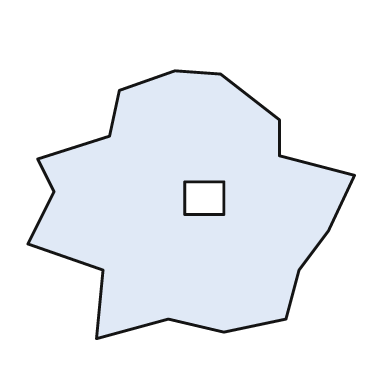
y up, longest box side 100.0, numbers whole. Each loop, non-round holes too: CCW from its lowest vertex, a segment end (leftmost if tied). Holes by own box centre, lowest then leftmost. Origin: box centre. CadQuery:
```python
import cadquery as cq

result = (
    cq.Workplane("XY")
    .moveTo(-29.0, -41.0)
    .lineTo(-7.0, -35.0)
    .lineTo(10.0, -39.0)
    .lineTo(29.0, -35.0)
    .lineTo(33.0, -20.0)
    .lineTo(42.0, -8.0)
    .lineTo(50.0, 9.0)
    .lineTo(27.0, 15.0)
    .lineTo(27.0, 26.0)
    .lineTo(9.0, 40.0)
    .lineTo(-5.0, 41.0)
    .lineTo(-22.0, 35.0)
    .lineTo(-25.0, 21.0)
    .lineTo(-47.0, 14.0)
    .lineTo(-42.0, 4.0)
    .lineTo(-50.0, -12.0)
    .lineTo(-27.0, -20.0)
    .close()
    .moveTo(-2.0, -3.0)
    .lineTo(10.0, -3.0)
    .lineTo(10.0, 7.0)
    .lineTo(-2.0, 7.0)
    .close()
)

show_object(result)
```